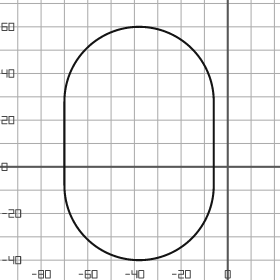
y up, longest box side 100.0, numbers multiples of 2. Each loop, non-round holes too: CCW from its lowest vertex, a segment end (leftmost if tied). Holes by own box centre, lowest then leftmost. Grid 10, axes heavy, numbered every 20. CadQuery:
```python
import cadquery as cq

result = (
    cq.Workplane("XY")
    .moveTo(-70.0, -8.0)
    .threePointArc((-38.0, -40.0), (-6.0, -8.0))
    .lineTo(-6.0, 28.0)
    .threePointArc((-38.0, 60.0), (-70.0, 28.0))
    .close()
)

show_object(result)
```